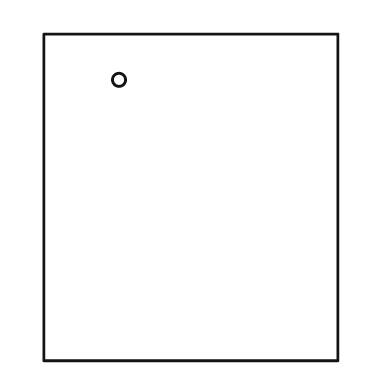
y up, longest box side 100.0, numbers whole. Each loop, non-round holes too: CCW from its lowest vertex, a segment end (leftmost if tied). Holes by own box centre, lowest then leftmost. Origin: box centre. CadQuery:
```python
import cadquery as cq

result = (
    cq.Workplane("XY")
    .moveTo(-45.0, -50.0)
    .lineTo(45.0, -50.0)
    .lineTo(45.0, 50.0)
    .lineTo(-45.0, 50.0)
    .close()
    .moveTo(-22.0, 36.0)
    .circle(2.0)
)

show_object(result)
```